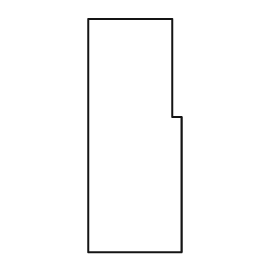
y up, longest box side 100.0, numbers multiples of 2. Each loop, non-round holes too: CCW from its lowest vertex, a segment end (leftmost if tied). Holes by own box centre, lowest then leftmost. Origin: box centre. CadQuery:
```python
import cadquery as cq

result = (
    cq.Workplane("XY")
    .moveTo(-20.0, -50.0)
    .lineTo(20.0, -50.0)
    .lineTo(20.0, 8.0)
    .lineTo(16.0, 8.0)
    .lineTo(16.0, 50.0)
    .lineTo(-20.0, 50.0)
    .close()
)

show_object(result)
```